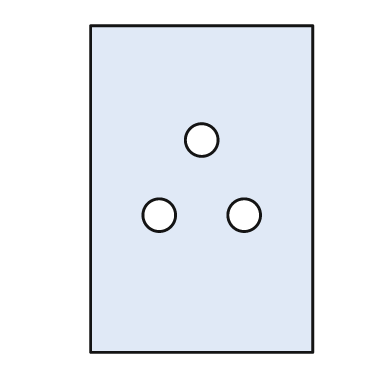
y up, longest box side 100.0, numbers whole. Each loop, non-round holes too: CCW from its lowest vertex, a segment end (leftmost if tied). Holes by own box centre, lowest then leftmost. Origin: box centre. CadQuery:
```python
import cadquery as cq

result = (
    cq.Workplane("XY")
    .moveTo(-34.0, -50.0)
    .lineTo(34.0, -50.0)
    .lineTo(34.0, 50.0)
    .lineTo(-34.0, 50.0)
    .close()
    .moveTo(-13.0, -8.0)
    .circle(5.0)
    .moveTo(13.0, -8.0)
    .circle(5.0)
    .moveTo(0.0, 15.0)
    .circle(5.0)
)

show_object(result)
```